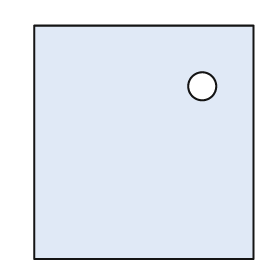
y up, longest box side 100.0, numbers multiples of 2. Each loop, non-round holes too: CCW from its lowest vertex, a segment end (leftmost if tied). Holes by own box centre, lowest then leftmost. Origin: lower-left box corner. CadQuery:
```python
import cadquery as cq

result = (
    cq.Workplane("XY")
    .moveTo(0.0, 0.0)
    .lineTo(94.0, 0.0)
    .lineTo(94.0, 100.0)
    .lineTo(0.0, 100.0)
    .close()
    .moveTo(72.0, 74.0)
    .circle(6.0)
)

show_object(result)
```